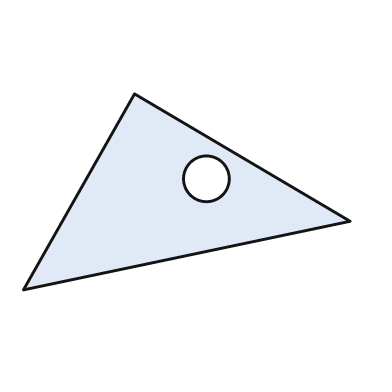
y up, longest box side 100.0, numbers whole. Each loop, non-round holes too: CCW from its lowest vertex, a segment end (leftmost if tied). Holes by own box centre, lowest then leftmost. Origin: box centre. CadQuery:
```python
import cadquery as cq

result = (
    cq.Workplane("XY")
    .moveTo(-50.0, -30.0)
    .lineTo(50.0, -9.0)
    .lineTo(-16.0, 30.0)
    .close()
    .moveTo(6.0, 4.0)
    .circle(7.0)
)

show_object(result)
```